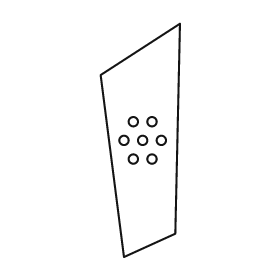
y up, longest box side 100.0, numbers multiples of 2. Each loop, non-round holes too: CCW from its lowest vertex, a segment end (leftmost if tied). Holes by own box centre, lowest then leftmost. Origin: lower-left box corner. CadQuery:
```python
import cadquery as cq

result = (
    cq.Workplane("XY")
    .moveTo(10.0, 0.0)
    .lineTo(32.0, 10.0)
    .lineTo(34.0, 100.0)
    .lineTo(0.0, 78.0)
    .close()
    .moveTo(14.0, 42.0)
    .circle(2.0)
    .moveTo(22.0, 42.0)
    .circle(2.0)
    .moveTo(10.0, 50.0)
    .circle(2.0)
    .moveTo(18.0, 50.0)
    .circle(2.0)
    .moveTo(26.0, 50.0)
    .circle(2.0)
    .moveTo(14.0, 58.0)
    .circle(2.0)
    .moveTo(22.0, 58.0)
    .circle(2.0)
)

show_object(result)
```